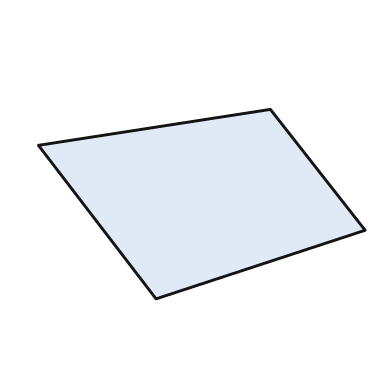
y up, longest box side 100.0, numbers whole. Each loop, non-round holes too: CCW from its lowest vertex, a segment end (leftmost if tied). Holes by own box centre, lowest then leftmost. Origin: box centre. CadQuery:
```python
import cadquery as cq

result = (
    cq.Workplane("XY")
    .moveTo(-14.0, -29.0)
    .lineTo(50.0, -8.0)
    .lineTo(21.0, 29.0)
    .lineTo(-50.0, 18.0)
    .close()
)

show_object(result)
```